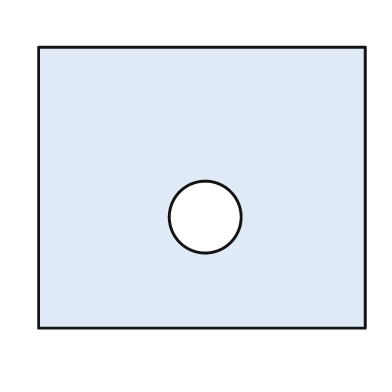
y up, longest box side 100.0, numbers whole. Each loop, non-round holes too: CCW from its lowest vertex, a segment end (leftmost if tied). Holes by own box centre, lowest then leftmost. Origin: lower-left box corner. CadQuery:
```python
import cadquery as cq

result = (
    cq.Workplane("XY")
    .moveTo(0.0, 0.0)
    .lineTo(100.0, 0.0)
    .lineTo(100.0, 86.0)
    .lineTo(0.0, 86.0)
    .close()
    .moveTo(51.0, 34.0)
    .circle(11.0)
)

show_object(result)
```